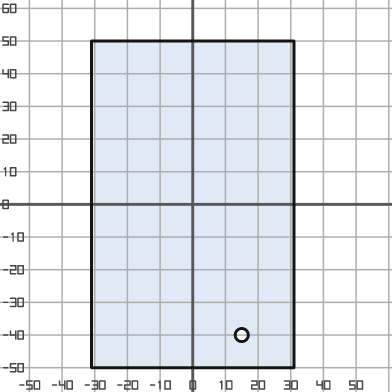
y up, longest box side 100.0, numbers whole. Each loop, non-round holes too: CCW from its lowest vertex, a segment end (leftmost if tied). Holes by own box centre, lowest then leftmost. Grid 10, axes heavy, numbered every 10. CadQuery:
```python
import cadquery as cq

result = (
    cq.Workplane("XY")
    .moveTo(-31.0, -50.0)
    .lineTo(31.0, -50.0)
    .lineTo(31.0, 50.0)
    .lineTo(-31.0, 50.0)
    .close()
    .moveTo(15.0, -40.0)
    .circle(2.0)
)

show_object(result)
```